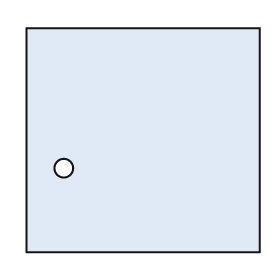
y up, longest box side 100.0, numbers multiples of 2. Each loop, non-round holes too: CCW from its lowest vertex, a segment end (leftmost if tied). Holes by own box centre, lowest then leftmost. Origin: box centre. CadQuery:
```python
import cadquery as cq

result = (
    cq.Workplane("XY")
    .moveTo(-50.0, -48.0)
    .lineTo(50.0, -48.0)
    .lineTo(50.0, 48.0)
    .lineTo(-50.0, 48.0)
    .close()
    .moveTo(-34.0, -12.0)
    .circle(4.0)
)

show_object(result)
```